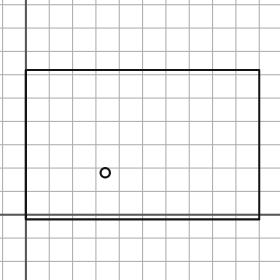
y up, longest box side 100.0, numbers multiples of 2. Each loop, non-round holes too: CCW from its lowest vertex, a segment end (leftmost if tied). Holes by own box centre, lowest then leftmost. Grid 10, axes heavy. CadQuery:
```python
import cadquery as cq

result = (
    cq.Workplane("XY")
    .moveTo(0.0, -2.0)
    .lineTo(100.0, -2.0)
    .lineTo(100.0, 62.0)
    .lineTo(0.0, 62.0)
    .close()
    .moveTo(34.0, 18.0)
    .circle(2.0)
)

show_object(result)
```